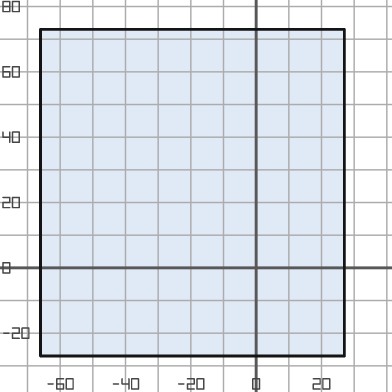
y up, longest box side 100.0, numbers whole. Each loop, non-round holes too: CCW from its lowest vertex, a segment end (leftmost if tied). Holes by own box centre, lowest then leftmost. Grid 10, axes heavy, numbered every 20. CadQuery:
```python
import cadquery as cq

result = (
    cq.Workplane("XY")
    .moveTo(-66.0, -27.0)
    .lineTo(27.0, -27.0)
    .lineTo(27.0, 73.0)
    .lineTo(-66.0, 73.0)
    .close()
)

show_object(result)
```